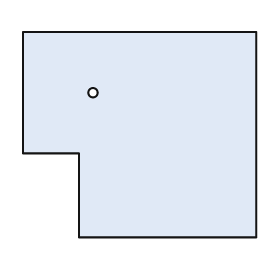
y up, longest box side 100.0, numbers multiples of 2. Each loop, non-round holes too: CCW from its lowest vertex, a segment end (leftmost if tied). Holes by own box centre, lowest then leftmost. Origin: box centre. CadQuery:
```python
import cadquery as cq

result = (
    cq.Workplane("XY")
    .moveTo(-26.0, -44.0)
    .lineTo(50.0, -44.0)
    .lineTo(50.0, 44.0)
    .lineTo(-50.0, 44.0)
    .lineTo(-50.0, -8.0)
    .lineTo(-26.0, -8.0)
    .close()
    .moveTo(-20.0, 18.0)
    .circle(2.0)
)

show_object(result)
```